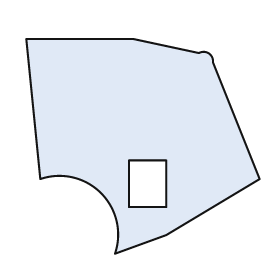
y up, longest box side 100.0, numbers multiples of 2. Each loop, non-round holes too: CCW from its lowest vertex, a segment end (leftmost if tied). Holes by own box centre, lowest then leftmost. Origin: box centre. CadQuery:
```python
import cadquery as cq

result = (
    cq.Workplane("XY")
    .moveTo(-12.0, -46.0)
    .lineTo(10.0, -38.0)
    .lineTo(50.0, -14.0)
    .lineTo(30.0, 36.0)
    .threePointArc((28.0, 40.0), (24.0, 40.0))
    .lineTo(-4.0, 46.0)
    .lineTo(-50.0, 46.0)
    .lineTo(-44.0, -14.0)
    .threePointArc((-18.0, -20.0), (-12.0, -46.0))
    .close()
    .moveTo(-6.0, -26.0)
    .lineTo(10.0, -26.0)
    .lineTo(10.0, -6.0)
    .lineTo(-6.0, -6.0)
    .close()
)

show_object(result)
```